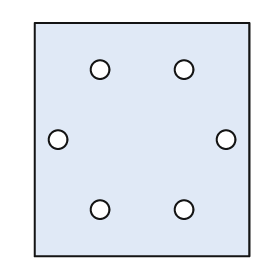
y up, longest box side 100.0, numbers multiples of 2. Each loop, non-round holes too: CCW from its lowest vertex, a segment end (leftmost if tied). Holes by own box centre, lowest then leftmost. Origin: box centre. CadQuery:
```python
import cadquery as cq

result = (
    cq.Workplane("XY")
    .moveTo(-46.0, -50.0)
    .lineTo(46.0, -50.0)
    .lineTo(46.0, 50.0)
    .lineTo(-46.0, 50.0)
    .close()
    .moveTo(-18.0, -30.0)
    .circle(4.0)
    .moveTo(18.0, -30.0)
    .circle(4.0)
    .moveTo(-36.0, 0.0)
    .circle(4.0)
    .moveTo(36.0, 0.0)
    .circle(4.0)
    .moveTo(-18.0, 30.0)
    .circle(4.0)
    .moveTo(18.0, 30.0)
    .circle(4.0)
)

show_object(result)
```